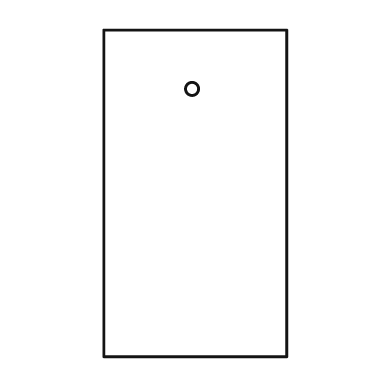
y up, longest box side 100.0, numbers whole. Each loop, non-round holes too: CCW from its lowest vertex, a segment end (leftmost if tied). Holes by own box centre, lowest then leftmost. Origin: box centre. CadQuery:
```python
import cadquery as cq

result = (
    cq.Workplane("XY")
    .moveTo(-28.0, -50.0)
    .lineTo(28.0, -50.0)
    .lineTo(28.0, 50.0)
    .lineTo(-28.0, 50.0)
    .close()
    .moveTo(-1.0, 32.0)
    .circle(2.0)
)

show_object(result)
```